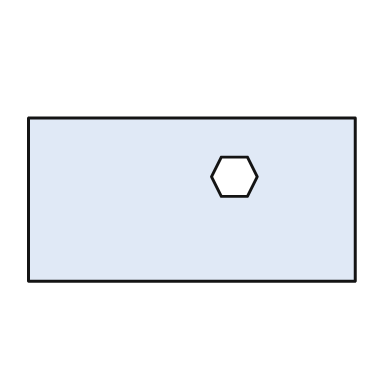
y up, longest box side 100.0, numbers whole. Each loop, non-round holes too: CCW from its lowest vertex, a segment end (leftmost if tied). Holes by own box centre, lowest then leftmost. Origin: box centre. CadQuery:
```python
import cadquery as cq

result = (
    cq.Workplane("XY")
    .moveTo(-50.0, -25.0)
    .lineTo(50.0, -25.0)
    .lineTo(50.0, 25.0)
    .lineTo(-50.0, 25.0)
    .close()
    .moveTo(9.0, 1.0)
    .lineTo(17.0, 1.0)
    .lineTo(20.0, 7.0)
    .lineTo(17.0, 13.0)
    .lineTo(9.0, 13.0)
    .lineTo(6.0, 7.0)
    .close()
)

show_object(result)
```